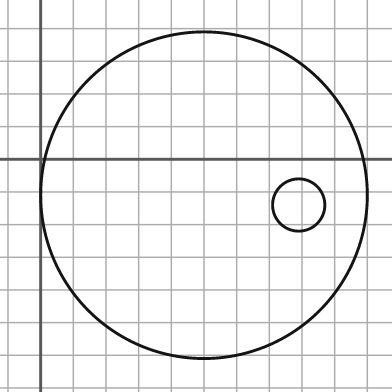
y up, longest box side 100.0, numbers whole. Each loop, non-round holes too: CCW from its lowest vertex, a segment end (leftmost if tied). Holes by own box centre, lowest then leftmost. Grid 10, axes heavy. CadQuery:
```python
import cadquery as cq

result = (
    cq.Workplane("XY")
    .moveTo(50.0, -11.0)
    .circle(50.0)
    .moveTo(79.0, -14.0)
    .circle(8.0)
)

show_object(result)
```